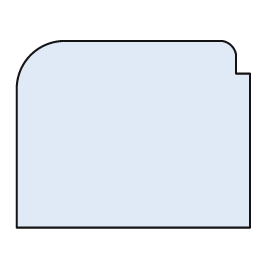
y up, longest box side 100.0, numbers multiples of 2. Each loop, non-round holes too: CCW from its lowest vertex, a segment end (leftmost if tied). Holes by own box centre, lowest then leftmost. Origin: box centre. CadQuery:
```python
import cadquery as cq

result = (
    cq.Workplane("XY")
    .moveTo(-50.0, -40.0)
    .lineTo(50.0, -40.0)
    .lineTo(50.0, 26.0)
    .lineTo(44.0, 26.0)
    .lineTo(44.0, 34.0)
    .threePointArc((42.0, 38.0), (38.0, 40.0))
    .lineTo(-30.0, 40.0)
    .threePointArc((-44.0, 34.0), (-50.0, 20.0))
    .close()
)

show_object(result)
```